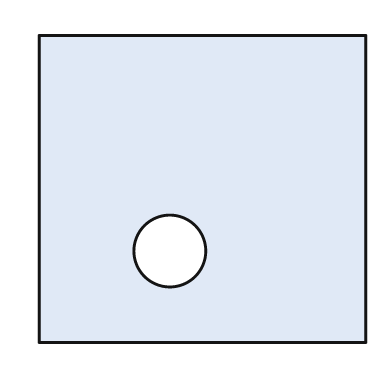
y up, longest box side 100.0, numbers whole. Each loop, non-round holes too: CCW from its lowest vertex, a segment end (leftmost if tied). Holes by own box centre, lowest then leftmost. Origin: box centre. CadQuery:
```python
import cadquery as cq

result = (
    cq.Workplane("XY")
    .moveTo(-50.0, -47.0)
    .lineTo(50.0, -47.0)
    .lineTo(50.0, 47.0)
    .lineTo(-50.0, 47.0)
    .close()
    .moveTo(-10.0, -19.0)
    .circle(11.0)
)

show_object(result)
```